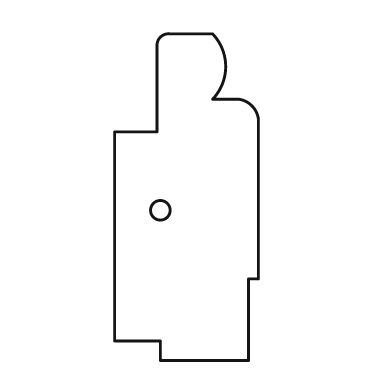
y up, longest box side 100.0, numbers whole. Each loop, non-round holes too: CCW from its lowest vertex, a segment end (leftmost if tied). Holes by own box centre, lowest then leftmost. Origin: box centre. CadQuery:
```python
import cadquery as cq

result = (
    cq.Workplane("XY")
    .moveTo(-8.0, -50.0)
    .lineTo(19.0, -50.0)
    .lineTo(19.0, -25.0)
    .lineTo(22.0, -25.0)
    .lineTo(22.0, 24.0)
    .threePointArc((20.0, 28.0), (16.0, 30.0))
    .lineTo(8.0, 30.0)
    .threePointArc((12.0, 40.0), (8.0, 50.0))
    .lineTo(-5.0, 50.0)
    .threePointArc((-8.0, 49.0), (-9.0, 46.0))
    .lineTo(-9.0, 20.0)
    .lineTo(-22.0, 20.0)
    .lineTo(-22.0, -44.0)
    .lineTo(-8.0, -44.0)
    .close()
    .moveTo(-8.0, -4.0)
    .circle(3.0)
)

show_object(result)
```